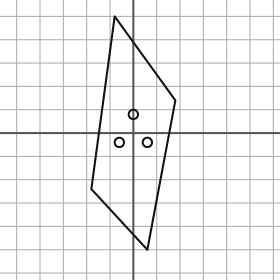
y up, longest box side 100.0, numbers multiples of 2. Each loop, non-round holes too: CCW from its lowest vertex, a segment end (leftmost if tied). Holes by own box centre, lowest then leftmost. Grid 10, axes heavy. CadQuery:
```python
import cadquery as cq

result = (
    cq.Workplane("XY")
    .moveTo(6.0, -50.0)
    .lineTo(18.0, 14.0)
    .lineTo(-8.0, 50.0)
    .lineTo(-18.0, -24.0)
    .close()
    .moveTo(-6.0, -4.0)
    .circle(2.0)
    .moveTo(6.0, -4.0)
    .circle(2.0)
    .moveTo(0.0, 8.0)
    .circle(2.0)
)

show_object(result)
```